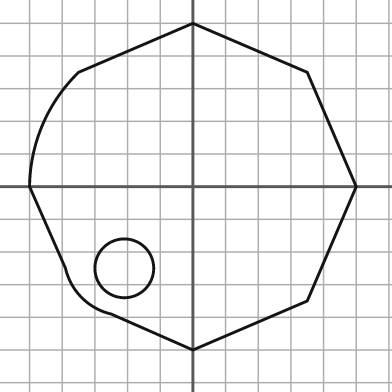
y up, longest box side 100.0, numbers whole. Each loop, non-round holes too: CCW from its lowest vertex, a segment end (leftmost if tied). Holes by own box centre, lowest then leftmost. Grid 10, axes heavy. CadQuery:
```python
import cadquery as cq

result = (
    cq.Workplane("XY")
    .moveTo(0.0, -50.0)
    .lineTo(35.0, -35.0)
    .lineTo(50.0, 0.0)
    .lineTo(35.0, 35.0)
    .lineTo(0.0, 50.0)
    .lineTo(-35.0, 35.0)
    .threePointArc((-46.0, 19.0), (-50.0, 0.0))
    .lineTo(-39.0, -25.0)
    .threePointArc((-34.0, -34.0), (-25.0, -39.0))
    .close()
    .moveTo(-21.0, -25.0)
    .circle(9.0)
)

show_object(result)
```